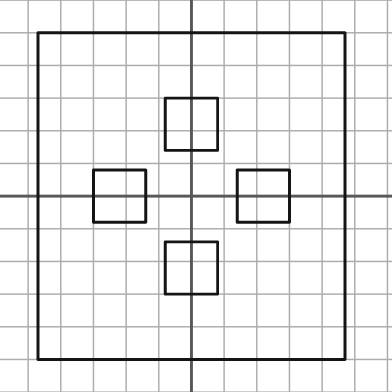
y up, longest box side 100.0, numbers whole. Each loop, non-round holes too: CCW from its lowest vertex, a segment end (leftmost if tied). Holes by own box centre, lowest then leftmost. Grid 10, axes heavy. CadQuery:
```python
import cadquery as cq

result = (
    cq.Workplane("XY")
    .moveTo(-47.0, -50.0)
    .lineTo(47.0, -50.0)
    .lineTo(47.0, 50.0)
    .lineTo(-47.0, 50.0)
    .close()
    .moveTo(-8.0, -30.0)
    .lineTo(8.0, -30.0)
    .lineTo(8.0, -14.0)
    .lineTo(-8.0, -14.0)
    .close()
    .moveTo(-30.0, -8.0)
    .lineTo(-14.0, -8.0)
    .lineTo(-14.0, 8.0)
    .lineTo(-30.0, 8.0)
    .close()
    .moveTo(14.0, -8.0)
    .lineTo(30.0, -8.0)
    .lineTo(30.0, 8.0)
    .lineTo(14.0, 8.0)
    .close()
    .moveTo(-8.0, 14.0)
    .lineTo(8.0, 14.0)
    .lineTo(8.0, 30.0)
    .lineTo(-8.0, 30.0)
    .close()
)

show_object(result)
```